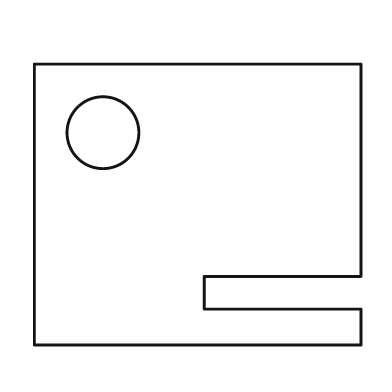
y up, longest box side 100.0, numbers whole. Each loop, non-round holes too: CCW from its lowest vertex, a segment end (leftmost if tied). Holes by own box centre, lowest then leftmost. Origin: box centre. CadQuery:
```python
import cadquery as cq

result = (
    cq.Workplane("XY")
    .moveTo(-50.0, -43.0)
    .lineTo(50.0, -43.0)
    .lineTo(50.0, -32.0)
    .lineTo(2.0, -32.0)
    .lineTo(2.0, -22.0)
    .lineTo(50.0, -22.0)
    .lineTo(50.0, 43.0)
    .lineTo(-50.0, 43.0)
    .close()
    .moveTo(-29.0, 22.0)
    .circle(11.0)
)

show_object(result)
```